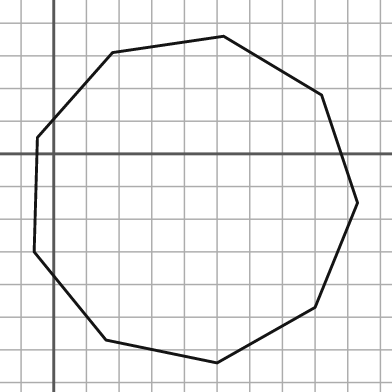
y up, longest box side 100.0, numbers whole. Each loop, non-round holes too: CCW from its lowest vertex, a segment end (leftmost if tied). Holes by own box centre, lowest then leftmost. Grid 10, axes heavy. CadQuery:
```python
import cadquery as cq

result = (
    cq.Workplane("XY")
    .moveTo(50.0, -64.0)
    .lineTo(80.0, -47.0)
    .lineTo(93.0, -15.0)
    .lineTo(82.0, 18.0)
    .lineTo(52.0, 36.0)
    .lineTo(18.0, 31.0)
    .lineTo(-5.0, 5.0)
    .lineTo(-6.0, -30.0)
    .lineTo(16.0, -57.0)
    .close()
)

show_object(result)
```